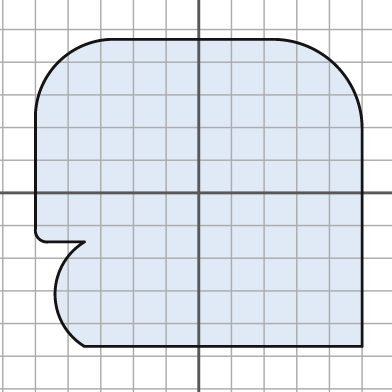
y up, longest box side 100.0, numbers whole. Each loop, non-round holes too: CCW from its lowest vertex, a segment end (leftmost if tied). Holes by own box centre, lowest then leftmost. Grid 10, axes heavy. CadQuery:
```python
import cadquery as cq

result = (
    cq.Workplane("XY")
    .moveTo(-35.0, -47.0)
    .lineTo(50.0, -47.0)
    .lineTo(50.0, 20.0)
    .threePointArc((42.0, 39.0), (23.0, 47.0))
    .lineTo(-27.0, 47.0)
    .threePointArc((-43.0, 40.0), (-50.0, 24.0))
    .lineTo(-50.0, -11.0)
    .threePointArc((-49.0, -14.0), (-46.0, -15.0))
    .lineTo(-35.0, -15.0)
    .threePointArc((-44.0, -31.0), (-35.0, -47.0))
    .close()
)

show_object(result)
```